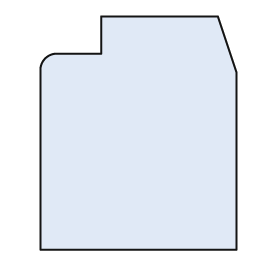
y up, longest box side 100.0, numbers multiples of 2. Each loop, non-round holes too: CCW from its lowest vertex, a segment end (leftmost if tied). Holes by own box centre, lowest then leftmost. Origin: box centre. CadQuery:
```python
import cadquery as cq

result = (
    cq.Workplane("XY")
    .moveTo(-42.0, -50.0)
    .lineTo(42.0, -50.0)
    .lineTo(42.0, 26.0)
    .lineTo(34.0, 50.0)
    .lineTo(-16.0, 50.0)
    .lineTo(-16.0, 34.0)
    .lineTo(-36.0, 34.0)
    .threePointArc((-40.0, 32.0), (-42.0, 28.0))
    .close()
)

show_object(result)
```